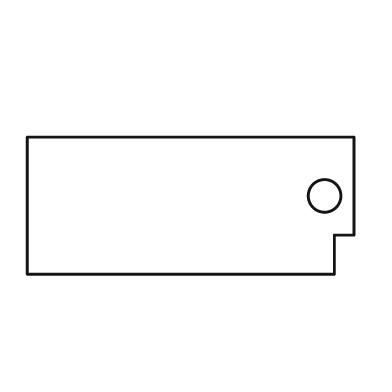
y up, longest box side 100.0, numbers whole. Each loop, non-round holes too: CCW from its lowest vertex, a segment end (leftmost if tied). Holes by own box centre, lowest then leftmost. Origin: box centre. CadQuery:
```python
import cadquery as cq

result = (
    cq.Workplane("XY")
    .moveTo(-50.0, -21.0)
    .lineTo(44.0, -21.0)
    .lineTo(44.0, -9.0)
    .lineTo(50.0, -9.0)
    .lineTo(50.0, 21.0)
    .lineTo(-50.0, 21.0)
    .close()
    .moveTo(41.0, 3.0)
    .circle(5.0)
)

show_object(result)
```